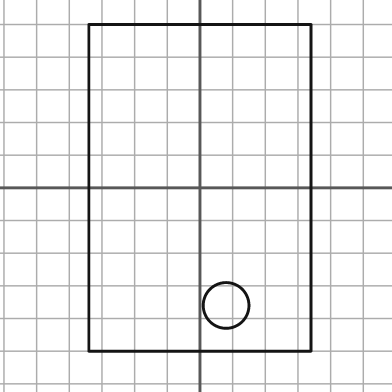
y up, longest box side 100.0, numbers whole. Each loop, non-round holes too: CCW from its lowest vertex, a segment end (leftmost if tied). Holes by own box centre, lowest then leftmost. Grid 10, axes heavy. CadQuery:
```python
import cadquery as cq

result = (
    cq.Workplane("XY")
    .moveTo(-34.0, -50.0)
    .lineTo(34.0, -50.0)
    .lineTo(34.0, 50.0)
    .lineTo(-34.0, 50.0)
    .close()
    .moveTo(8.0, -36.0)
    .circle(7.0)
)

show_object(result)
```